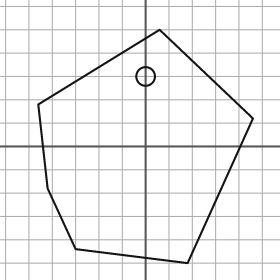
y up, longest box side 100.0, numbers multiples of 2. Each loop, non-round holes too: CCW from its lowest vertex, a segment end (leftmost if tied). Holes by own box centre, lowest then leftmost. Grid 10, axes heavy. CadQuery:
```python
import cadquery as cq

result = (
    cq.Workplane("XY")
    .moveTo(18.0, -50.0)
    .lineTo(46.0, 12.0)
    .lineTo(6.0, 50.0)
    .lineTo(-46.0, 18.0)
    .lineTo(-42.0, -18.0)
    .lineTo(-30.0, -44.0)
    .close()
    .moveTo(0.0, 30.0)
    .circle(4.0)
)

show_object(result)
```